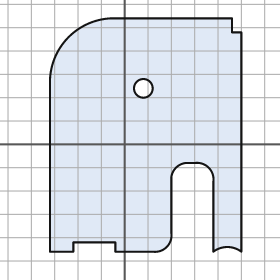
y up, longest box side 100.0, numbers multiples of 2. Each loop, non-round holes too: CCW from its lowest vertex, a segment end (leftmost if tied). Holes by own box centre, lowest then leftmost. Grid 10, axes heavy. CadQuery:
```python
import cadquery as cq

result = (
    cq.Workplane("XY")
    .moveTo(-32.0, -46.0)
    .lineTo(-22.0, -46.0)
    .lineTo(-22.0, -42.0)
    .lineTo(-4.0, -42.0)
    .lineTo(-4.0, -46.0)
    .lineTo(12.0, -46.0)
    .threePointArc((18.0, -44.0), (20.0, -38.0))
    .lineTo(20.0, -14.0)
    .threePointArc((22.0, -10.0), (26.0, -8.0))
    .lineTo(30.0, -8.0)
    .threePointArc((36.0, -10.0), (38.0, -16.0))
    .lineTo(38.0, -46.0)
    .threePointArc((44.0, -44.0), (50.0, -46.0))
    .lineTo(50.0, 48.0)
    .lineTo(46.0, 48.0)
    .lineTo(46.0, 54.0)
    .lineTo(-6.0, 54.0)
    .threePointArc((-24.0, 46.0), (-32.0, 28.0))
    .close()
    .moveTo(8.0, 24.0)
    .circle(4.0)
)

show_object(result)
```